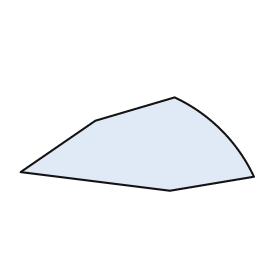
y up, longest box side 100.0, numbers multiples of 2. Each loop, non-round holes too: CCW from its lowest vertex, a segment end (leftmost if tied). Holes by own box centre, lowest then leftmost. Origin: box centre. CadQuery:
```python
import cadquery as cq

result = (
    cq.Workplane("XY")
    .moveTo(14.0, -20.0)
    .lineTo(50.0, -14.0)
    .threePointArc((36.0, 6.0), (16.0, 20.0))
    .lineTo(-18.0, 10.0)
    .lineTo(-50.0, -12.0)
    .close()
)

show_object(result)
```